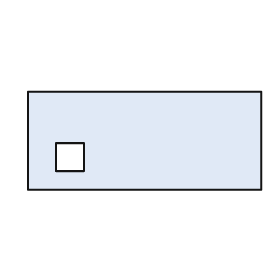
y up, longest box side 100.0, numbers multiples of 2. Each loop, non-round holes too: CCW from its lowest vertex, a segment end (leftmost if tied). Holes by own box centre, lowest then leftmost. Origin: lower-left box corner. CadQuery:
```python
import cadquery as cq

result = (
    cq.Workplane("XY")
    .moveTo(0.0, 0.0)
    .lineTo(100.0, 0.0)
    .lineTo(100.0, 42.0)
    .lineTo(0.0, 42.0)
    .close()
    .moveTo(12.0, 8.0)
    .lineTo(24.0, 8.0)
    .lineTo(24.0, 20.0)
    .lineTo(12.0, 20.0)
    .close()
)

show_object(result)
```